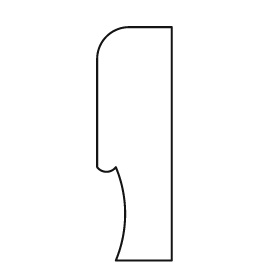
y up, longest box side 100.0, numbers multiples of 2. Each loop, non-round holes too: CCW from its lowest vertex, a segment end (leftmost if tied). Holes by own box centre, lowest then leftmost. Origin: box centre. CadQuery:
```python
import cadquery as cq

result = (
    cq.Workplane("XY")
    .moveTo(-8.0, -50.0)
    .lineTo(16.0, -50.0)
    .lineTo(16.0, 50.0)
    .lineTo(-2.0, 50.0)
    .threePointArc((-12.0, 46.0), (-16.0, 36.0))
    .lineTo(-16.0, -10.0)
    .threePointArc((-12.0, -12.0), (-8.0, -10.0))
    .threePointArc((-4.0, -30.0), (-8.0, -50.0))
    .close()
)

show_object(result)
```